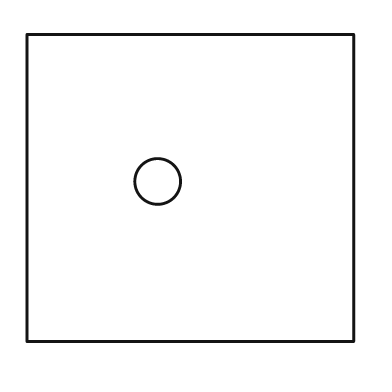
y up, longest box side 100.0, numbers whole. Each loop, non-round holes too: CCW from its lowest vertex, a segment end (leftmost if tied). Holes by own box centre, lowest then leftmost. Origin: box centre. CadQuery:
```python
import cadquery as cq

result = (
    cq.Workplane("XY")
    .moveTo(-50.0, -47.0)
    .lineTo(50.0, -47.0)
    .lineTo(50.0, 47.0)
    .lineTo(-50.0, 47.0)
    .close()
    .moveTo(-10.0, 2.0)
    .circle(7.0)
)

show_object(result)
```